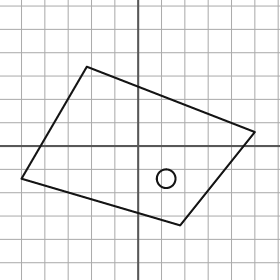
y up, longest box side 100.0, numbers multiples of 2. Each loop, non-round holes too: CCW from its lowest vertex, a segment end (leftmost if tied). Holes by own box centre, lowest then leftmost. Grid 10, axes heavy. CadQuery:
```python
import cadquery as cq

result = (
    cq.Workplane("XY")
    .moveTo(18.0, -34.0)
    .lineTo(50.0, 6.0)
    .lineTo(-22.0, 34.0)
    .lineTo(-50.0, -14.0)
    .close()
    .moveTo(12.0, -14.0)
    .circle(4.0)
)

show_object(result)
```